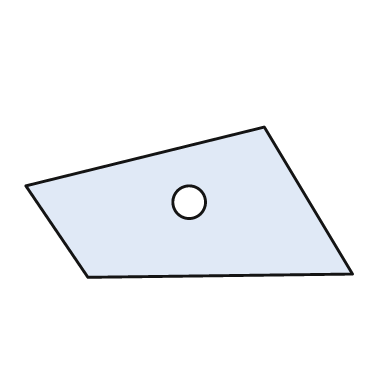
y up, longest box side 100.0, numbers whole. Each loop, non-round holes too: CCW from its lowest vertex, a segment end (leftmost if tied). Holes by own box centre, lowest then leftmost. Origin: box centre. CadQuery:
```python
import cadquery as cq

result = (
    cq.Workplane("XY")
    .moveTo(-31.0, -23.0)
    .lineTo(50.0, -22.0)
    .lineTo(23.0, 23.0)
    .lineTo(-50.0, 5.0)
    .close()
    .moveTo(0.0, 0.0)
    .circle(5.0)
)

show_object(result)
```